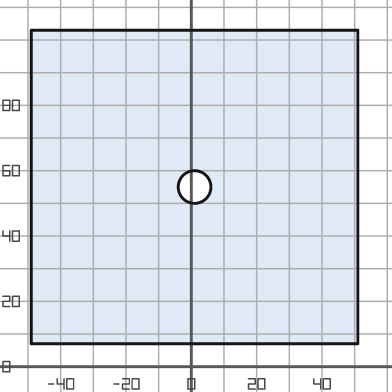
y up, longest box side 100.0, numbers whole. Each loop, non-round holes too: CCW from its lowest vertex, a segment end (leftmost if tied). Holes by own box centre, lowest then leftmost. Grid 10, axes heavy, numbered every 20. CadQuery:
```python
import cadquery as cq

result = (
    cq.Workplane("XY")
    .moveTo(-49.0, 7.0)
    .lineTo(51.0, 7.0)
    .lineTo(51.0, 103.0)
    .lineTo(-49.0, 103.0)
    .close()
    .moveTo(1.0, 55.0)
    .circle(5.0)
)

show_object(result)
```